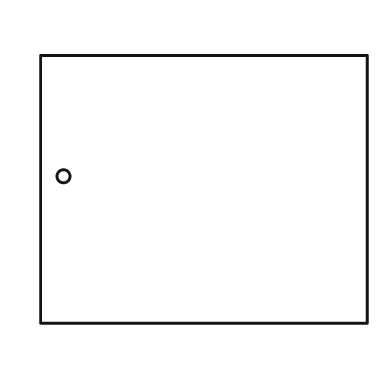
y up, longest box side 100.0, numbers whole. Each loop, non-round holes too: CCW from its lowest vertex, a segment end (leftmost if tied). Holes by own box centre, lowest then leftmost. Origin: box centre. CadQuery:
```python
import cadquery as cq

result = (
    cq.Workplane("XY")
    .moveTo(-50.0, -41.0)
    .lineTo(50.0, -41.0)
    .lineTo(50.0, 41.0)
    .lineTo(-50.0, 41.0)
    .close()
    .moveTo(-43.0, 4.0)
    .circle(2.0)
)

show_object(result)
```